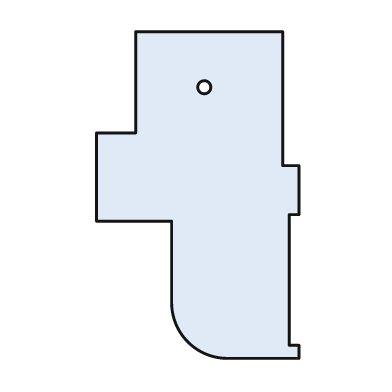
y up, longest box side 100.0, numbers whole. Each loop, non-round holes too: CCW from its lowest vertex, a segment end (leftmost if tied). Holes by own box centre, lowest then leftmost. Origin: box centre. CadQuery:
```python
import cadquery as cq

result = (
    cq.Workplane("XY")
    .moveTo(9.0, -50.0)
    .lineTo(31.0, -50.0)
    .lineTo(31.0, -46.0)
    .lineTo(28.0, -46.0)
    .lineTo(28.0, -6.0)
    .lineTo(31.0, -6.0)
    .lineTo(31.0, 9.0)
    .lineTo(26.0, 9.0)
    .lineTo(26.0, 50.0)
    .lineTo(-19.0, 50.0)
    .lineTo(-19.0, 19.0)
    .lineTo(-31.0, 19.0)
    .lineTo(-31.0, -8.0)
    .lineTo(-8.0, -8.0)
    .lineTo(-8.0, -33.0)
    .threePointArc((-3.0, -45.0), (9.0, -50.0))
    .close()
    .moveTo(2.0, 33.0)
    .circle(2.0)
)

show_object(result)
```